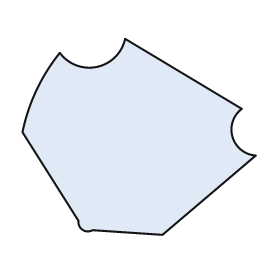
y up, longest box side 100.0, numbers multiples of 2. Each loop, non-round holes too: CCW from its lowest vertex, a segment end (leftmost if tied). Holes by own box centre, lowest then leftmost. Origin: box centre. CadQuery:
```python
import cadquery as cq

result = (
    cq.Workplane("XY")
    .moveTo(10.0, -42.0)
    .lineTo(50.0, -8.0)
    .threePointArc((40.0, 0.0), (44.0, 12.0))
    .lineTo(-6.0, 42.0)
    .threePointArc((-18.0, 30.0), (-34.0, 36.0))
    .threePointArc((-44.0, 20.0), (-50.0, 2.0))
    .lineTo(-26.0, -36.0)
    .threePointArc((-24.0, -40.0), (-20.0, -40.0))
    .close()
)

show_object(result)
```